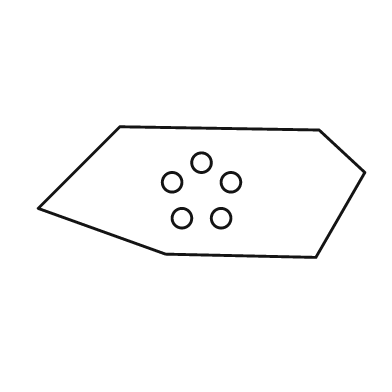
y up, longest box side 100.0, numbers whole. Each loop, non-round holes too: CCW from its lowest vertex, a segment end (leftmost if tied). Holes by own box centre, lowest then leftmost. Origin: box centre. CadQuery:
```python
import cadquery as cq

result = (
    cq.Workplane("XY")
    .moveTo(35.0, -20.0)
    .lineTo(50.0, 6.0)
    .lineTo(36.0, 19.0)
    .lineTo(-25.0, 20.0)
    .lineTo(-50.0, -5.0)
    .lineTo(-11.0, -19.0)
    .close()
    .moveTo(-6.0, -8.0)
    .circle(3.0)
    .moveTo(6.0, -8.0)
    .circle(3.0)
    .moveTo(-9.0, 3.0)
    .circle(3.0)
    .moveTo(9.0, 3.0)
    .circle(3.0)
    .moveTo(0.0, 9.0)
    .circle(3.0)
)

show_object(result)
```